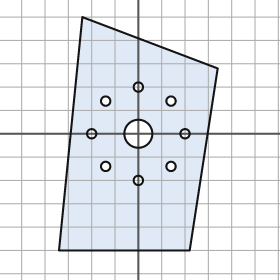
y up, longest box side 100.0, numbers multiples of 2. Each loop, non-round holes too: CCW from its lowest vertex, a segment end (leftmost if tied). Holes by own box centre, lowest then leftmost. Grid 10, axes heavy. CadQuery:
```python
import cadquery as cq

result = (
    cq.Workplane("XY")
    .moveTo(-34.0, -50.0)
    .lineTo(22.0, -50.0)
    .lineTo(34.0, 28.0)
    .lineTo(-24.0, 50.0)
    .close()
    .moveTo(0.0, -20.0)
    .circle(2.0)
    .moveTo(-14.0, -14.0)
    .circle(2.0)
    .moveTo(14.0, -14.0)
    .circle(2.0)
    .moveTo(-20.0, 0.0)
    .circle(2.0)
    .moveTo(0.0, 0.0)
    .circle(6.0)
    .moveTo(20.0, 0.0)
    .circle(2.0)
    .moveTo(-14.0, 14.0)
    .circle(2.0)
    .moveTo(14.0, 14.0)
    .circle(2.0)
    .moveTo(0.0, 20.0)
    .circle(2.0)
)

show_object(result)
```